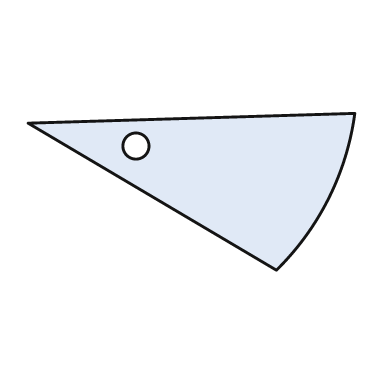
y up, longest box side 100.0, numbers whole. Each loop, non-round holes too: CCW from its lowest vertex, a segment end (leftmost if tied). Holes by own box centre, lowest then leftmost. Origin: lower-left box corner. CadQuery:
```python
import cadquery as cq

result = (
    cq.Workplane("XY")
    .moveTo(76.0, 0.0)
    .threePointArc((92.0, 22.0), (100.0, 48.0))
    .lineTo(0.0, 45.0)
    .close()
    .moveTo(33.0, 38.0)
    .circle(4.0)
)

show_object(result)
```